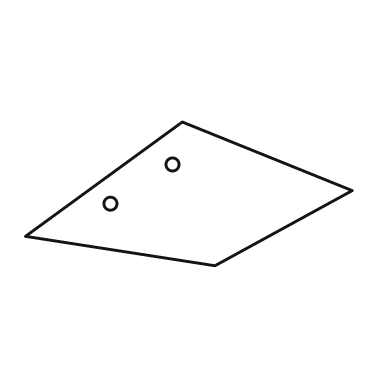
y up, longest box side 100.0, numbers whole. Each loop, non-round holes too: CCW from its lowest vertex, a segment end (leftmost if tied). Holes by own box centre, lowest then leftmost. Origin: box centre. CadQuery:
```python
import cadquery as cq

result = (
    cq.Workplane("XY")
    .moveTo(8.0, -22.0)
    .lineTo(50.0, 1.0)
    .lineTo(-2.0, 22.0)
    .lineTo(-50.0, -13.0)
    .close()
    .moveTo(-24.0, -3.0)
    .circle(2.0)
    .moveTo(-5.0, 9.0)
    .circle(2.0)
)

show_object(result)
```